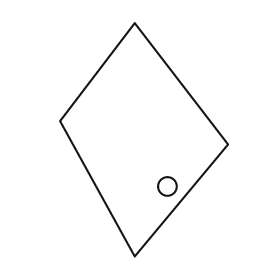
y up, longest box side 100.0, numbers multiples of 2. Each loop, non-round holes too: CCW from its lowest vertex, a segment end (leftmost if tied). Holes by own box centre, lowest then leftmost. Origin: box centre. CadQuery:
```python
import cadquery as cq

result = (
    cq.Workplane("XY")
    .moveTo(-4.0, -50.0)
    .lineTo(36.0, -2.0)
    .lineTo(-4.0, 50.0)
    .lineTo(-36.0, 8.0)
    .close()
    .moveTo(10.0, -20.0)
    .circle(4.0)
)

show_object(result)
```